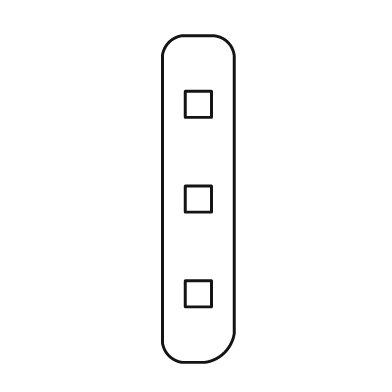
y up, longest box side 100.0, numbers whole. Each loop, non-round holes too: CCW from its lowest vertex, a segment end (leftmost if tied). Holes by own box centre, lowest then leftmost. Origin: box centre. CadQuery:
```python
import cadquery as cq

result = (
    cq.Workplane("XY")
    .moveTo(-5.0, -50.0)
    .lineTo(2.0, -50.0)
    .threePointArc((8.0, -47.0), (11.0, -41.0))
    .lineTo(11.0, 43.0)
    .threePointArc((9.0, 48.0), (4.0, 50.0))
    .lineTo(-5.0, 50.0)
    .threePointArc((-9.0, 48.0), (-11.0, 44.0))
    .lineTo(-11.0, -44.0)
    .threePointArc((-9.0, -48.0), (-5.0, -50.0))
    .close()
    .moveTo(-4.0, -33.0)
    .lineTo(4.0, -33.0)
    .lineTo(4.0, -25.0)
    .lineTo(-4.0, -25.0)
    .close()
    .moveTo(-4.0, -4.0)
    .lineTo(4.0, -4.0)
    .lineTo(4.0, 4.0)
    .lineTo(-4.0, 4.0)
    .close()
    .moveTo(-4.0, 25.0)
    .lineTo(4.0, 25.0)
    .lineTo(4.0, 33.0)
    .lineTo(-4.0, 33.0)
    .close()
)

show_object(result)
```